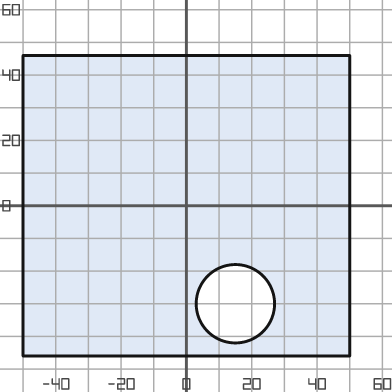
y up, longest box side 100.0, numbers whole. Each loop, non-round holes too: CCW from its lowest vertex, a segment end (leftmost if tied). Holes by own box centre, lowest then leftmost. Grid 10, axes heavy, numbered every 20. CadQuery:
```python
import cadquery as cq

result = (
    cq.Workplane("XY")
    .moveTo(-50.0, -46.0)
    .lineTo(50.0, -46.0)
    .lineTo(50.0, 46.0)
    .lineTo(-50.0, 46.0)
    .close()
    .moveTo(15.0, -30.0)
    .circle(12.0)
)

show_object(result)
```